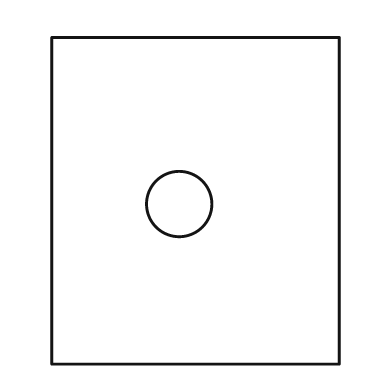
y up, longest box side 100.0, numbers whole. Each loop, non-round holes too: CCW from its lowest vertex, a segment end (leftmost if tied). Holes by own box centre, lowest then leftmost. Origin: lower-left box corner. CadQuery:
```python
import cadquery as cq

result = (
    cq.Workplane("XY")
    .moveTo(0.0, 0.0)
    .lineTo(88.0, 0.0)
    .lineTo(88.0, 100.0)
    .lineTo(0.0, 100.0)
    .close()
    .moveTo(39.0, 49.0)
    .circle(10.0)
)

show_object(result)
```